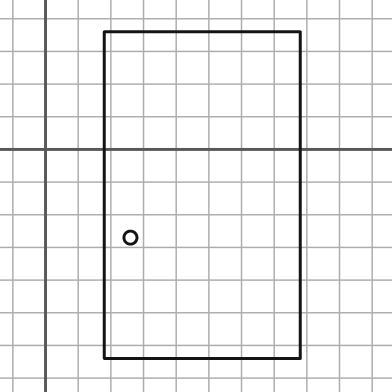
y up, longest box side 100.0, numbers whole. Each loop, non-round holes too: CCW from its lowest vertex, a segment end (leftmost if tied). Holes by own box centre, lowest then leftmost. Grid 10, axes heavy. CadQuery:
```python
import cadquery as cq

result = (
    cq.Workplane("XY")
    .moveTo(18.0, -64.0)
    .lineTo(78.0, -64.0)
    .lineTo(78.0, 36.0)
    .lineTo(18.0, 36.0)
    .close()
    .moveTo(26.0, -27.0)
    .circle(2.0)
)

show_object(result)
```